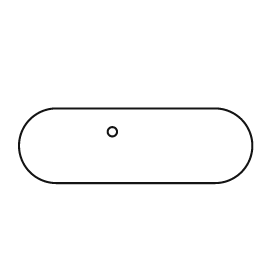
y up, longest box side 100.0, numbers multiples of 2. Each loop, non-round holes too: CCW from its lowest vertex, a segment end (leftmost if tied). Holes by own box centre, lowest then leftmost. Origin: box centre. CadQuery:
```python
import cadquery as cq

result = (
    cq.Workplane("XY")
    .moveTo(-34.0, -16.0)
    .lineTo(34.0, -16.0)
    .threePointArc((50.0, 0.0), (34.0, 16.0))
    .lineTo(-34.0, 16.0)
    .threePointArc((-50.0, 0.0), (-34.0, -16.0))
    .close()
    .moveTo(-10.0, 6.0)
    .circle(2.0)
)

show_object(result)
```